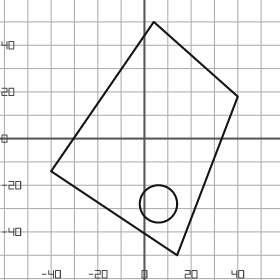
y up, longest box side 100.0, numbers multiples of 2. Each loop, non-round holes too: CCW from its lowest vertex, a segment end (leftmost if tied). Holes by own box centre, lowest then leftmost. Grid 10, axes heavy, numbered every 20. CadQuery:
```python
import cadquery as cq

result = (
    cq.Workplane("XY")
    .moveTo(14.0, -50.0)
    .lineTo(40.0, 18.0)
    .lineTo(4.0, 50.0)
    .lineTo(-40.0, -14.0)
    .close()
    .moveTo(6.0, -28.0)
    .circle(8.0)
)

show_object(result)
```